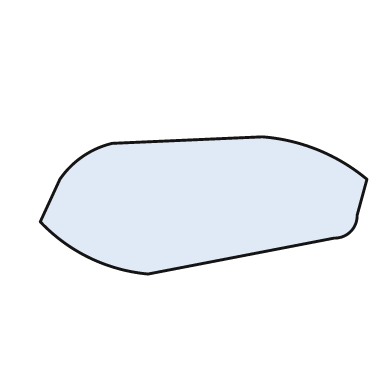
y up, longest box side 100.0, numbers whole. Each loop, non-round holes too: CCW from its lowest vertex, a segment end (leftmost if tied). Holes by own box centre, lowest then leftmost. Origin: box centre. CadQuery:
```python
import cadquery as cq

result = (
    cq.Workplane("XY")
    .moveTo(-17.0, -21.0)
    .lineTo(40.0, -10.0)
    .threePointArc((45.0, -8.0), (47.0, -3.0))
    .lineTo(50.0, 8.0)
    .threePointArc((35.0, 17.0), (18.0, 21.0))
    .lineTo(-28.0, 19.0)
    .threePointArc((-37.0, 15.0), (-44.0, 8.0))
    .lineTo(-50.0, -5.0)
    .threePointArc((-35.0, -16.0), (-17.0, -21.0))
    .close()
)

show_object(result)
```